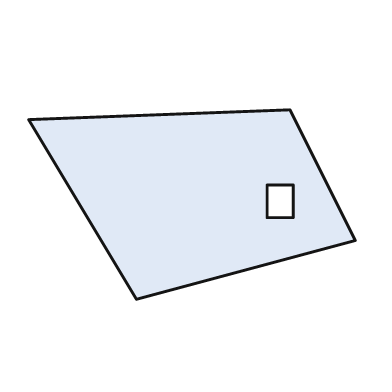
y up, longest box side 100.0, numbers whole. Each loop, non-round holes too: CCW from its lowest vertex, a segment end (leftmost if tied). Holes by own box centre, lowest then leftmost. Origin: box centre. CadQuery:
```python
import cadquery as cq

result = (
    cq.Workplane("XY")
    .moveTo(-17.0, -29.0)
    .lineTo(50.0, -11.0)
    .lineTo(30.0, 29.0)
    .lineTo(-50.0, 26.0)
    .close()
    .moveTo(23.0, -4.0)
    .lineTo(31.0, -4.0)
    .lineTo(31.0, 6.0)
    .lineTo(23.0, 6.0)
    .close()
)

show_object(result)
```